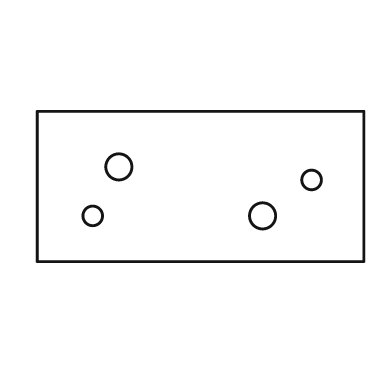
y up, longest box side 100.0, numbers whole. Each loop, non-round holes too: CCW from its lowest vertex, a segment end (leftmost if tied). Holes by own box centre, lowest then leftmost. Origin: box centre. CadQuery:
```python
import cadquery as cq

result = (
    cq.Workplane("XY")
    .moveTo(-50.0, -23.0)
    .lineTo(50.0, -23.0)
    .lineTo(50.0, 23.0)
    .lineTo(-50.0, 23.0)
    .close()
    .moveTo(-33.0, -9.0)
    .circle(3.0)
    .moveTo(19.0, -9.0)
    .circle(4.0)
    .moveTo(34.0, 2.0)
    .circle(3.0)
    .moveTo(-25.0, 6.0)
    .circle(4.0)
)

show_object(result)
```